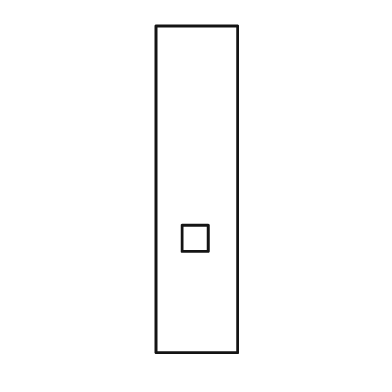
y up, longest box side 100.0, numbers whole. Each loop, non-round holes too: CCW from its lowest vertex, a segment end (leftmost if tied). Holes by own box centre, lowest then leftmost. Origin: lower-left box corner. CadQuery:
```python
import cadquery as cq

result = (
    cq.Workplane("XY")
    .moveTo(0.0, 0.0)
    .lineTo(25.0, 0.0)
    .lineTo(25.0, 100.0)
    .lineTo(0.0, 100.0)
    .close()
    .moveTo(8.0, 31.0)
    .lineTo(16.0, 31.0)
    .lineTo(16.0, 39.0)
    .lineTo(8.0, 39.0)
    .close()
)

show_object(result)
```